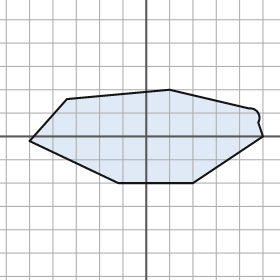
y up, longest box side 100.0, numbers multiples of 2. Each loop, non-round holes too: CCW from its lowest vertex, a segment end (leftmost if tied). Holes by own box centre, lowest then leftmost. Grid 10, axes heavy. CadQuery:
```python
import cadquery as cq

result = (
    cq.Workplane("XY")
    .moveTo(-12.0, -20.0)
    .lineTo(20.0, -20.0)
    .lineTo(50.0, 0.0)
    .lineTo(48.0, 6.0)
    .threePointArc((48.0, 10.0), (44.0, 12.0))
    .lineTo(10.0, 20.0)
    .lineTo(-34.0, 16.0)
    .lineTo(-50.0, -2.0)
    .close()
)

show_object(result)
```